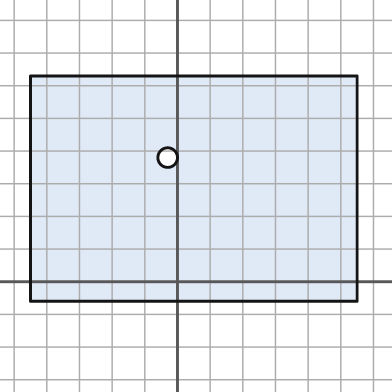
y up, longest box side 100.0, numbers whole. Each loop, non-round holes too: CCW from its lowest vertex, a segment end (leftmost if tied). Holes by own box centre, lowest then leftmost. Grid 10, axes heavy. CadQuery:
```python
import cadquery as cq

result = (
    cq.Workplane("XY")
    .moveTo(-45.0, -6.0)
    .lineTo(55.0, -6.0)
    .lineTo(55.0, 63.0)
    .lineTo(-45.0, 63.0)
    .close()
    .moveTo(-3.0, 38.0)
    .circle(3.0)
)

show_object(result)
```